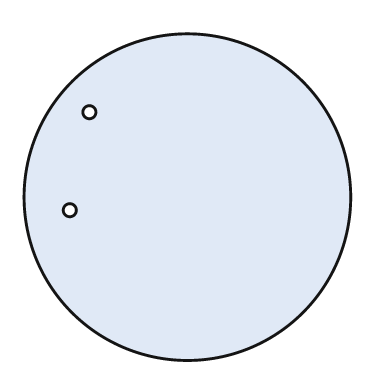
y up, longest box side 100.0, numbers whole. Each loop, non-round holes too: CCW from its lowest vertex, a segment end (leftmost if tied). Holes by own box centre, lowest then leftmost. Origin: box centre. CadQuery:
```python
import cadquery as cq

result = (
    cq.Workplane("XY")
    .moveTo(0.0, 0.0)
    .circle(50.0)
    .moveTo(-36.0, -4.0)
    .circle(2.0)
    .moveTo(-30.0, 26.0)
    .circle(2.0)
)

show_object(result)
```